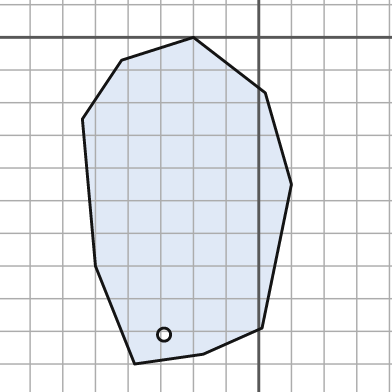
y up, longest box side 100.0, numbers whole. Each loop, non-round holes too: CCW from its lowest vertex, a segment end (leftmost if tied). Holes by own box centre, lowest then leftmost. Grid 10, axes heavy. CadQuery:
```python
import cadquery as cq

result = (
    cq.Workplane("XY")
    .moveTo(-38.0, -100.0)
    .lineTo(-17.0, -97.0)
    .lineTo(1.0, -89.0)
    .lineTo(10.0, -45.0)
    .lineTo(2.0, -17.0)
    .lineTo(-20.0, 0.0)
    .lineTo(-42.0, -7.0)
    .lineTo(-54.0, -25.0)
    .lineTo(-50.0, -70.0)
    .close()
    .moveTo(-29.0, -91.0)
    .circle(2.0)
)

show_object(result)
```